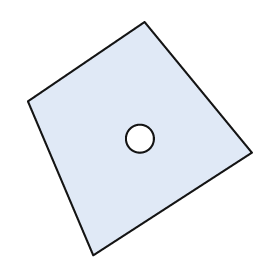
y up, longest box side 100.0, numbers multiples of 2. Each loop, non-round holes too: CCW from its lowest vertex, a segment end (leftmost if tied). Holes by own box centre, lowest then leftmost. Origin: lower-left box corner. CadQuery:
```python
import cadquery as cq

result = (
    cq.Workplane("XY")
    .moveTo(28.0, 0.0)
    .lineTo(96.0, 44.0)
    .lineTo(50.0, 100.0)
    .lineTo(0.0, 66.0)
    .close()
    .moveTo(48.0, 50.0)
    .circle(6.0)
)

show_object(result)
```